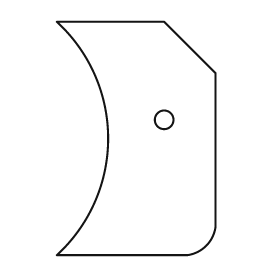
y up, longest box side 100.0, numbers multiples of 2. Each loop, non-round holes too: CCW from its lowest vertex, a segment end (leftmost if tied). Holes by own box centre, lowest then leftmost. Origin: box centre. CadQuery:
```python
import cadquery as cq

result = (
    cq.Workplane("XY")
    .moveTo(-34.0, -50.0)
    .lineTo(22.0, -50.0)
    .threePointArc((30.0, -46.0), (34.0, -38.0))
    .lineTo(34.0, 28.0)
    .lineTo(12.0, 50.0)
    .lineTo(-34.0, 50.0)
    .threePointArc((-12.0, 0.0), (-34.0, -50.0))
    .close()
    .moveTo(12.0, 8.0)
    .circle(4.0)
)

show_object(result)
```